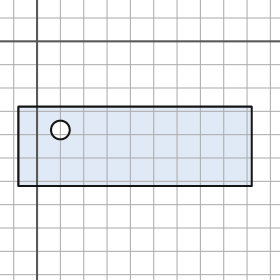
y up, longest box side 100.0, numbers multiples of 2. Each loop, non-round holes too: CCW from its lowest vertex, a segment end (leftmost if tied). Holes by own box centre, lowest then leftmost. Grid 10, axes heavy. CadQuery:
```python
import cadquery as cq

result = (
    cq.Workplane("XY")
    .moveTo(-8.0, -62.0)
    .lineTo(92.0, -62.0)
    .lineTo(92.0, -28.0)
    .lineTo(-8.0, -28.0)
    .close()
    .moveTo(10.0, -38.0)
    .circle(4.0)
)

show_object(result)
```